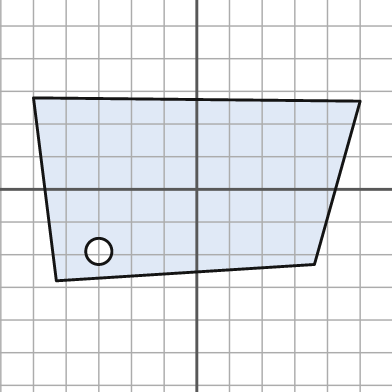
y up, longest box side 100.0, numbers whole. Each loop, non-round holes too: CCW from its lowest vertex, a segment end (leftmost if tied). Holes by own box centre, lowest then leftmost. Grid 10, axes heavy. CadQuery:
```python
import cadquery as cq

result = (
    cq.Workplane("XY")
    .moveTo(-43.0, -28.0)
    .lineTo(36.0, -23.0)
    .lineTo(50.0, 27.0)
    .lineTo(-50.0, 28.0)
    .close()
    .moveTo(-30.0, -19.0)
    .circle(4.0)
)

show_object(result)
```